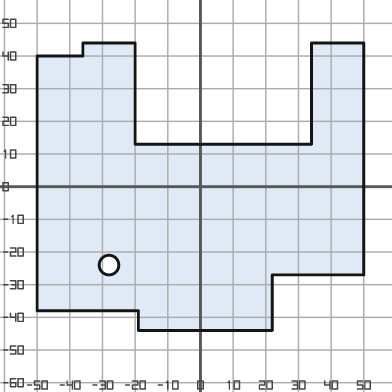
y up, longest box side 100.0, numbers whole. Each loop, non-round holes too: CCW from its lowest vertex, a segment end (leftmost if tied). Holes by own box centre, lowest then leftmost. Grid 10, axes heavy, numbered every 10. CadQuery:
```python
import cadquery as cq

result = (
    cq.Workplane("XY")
    .moveTo(-19.0, -44.0)
    .lineTo(22.0, -44.0)
    .lineTo(22.0, -27.0)
    .lineTo(50.0, -27.0)
    .lineTo(50.0, 44.0)
    .lineTo(34.0, 44.0)
    .lineTo(34.0, 13.0)
    .lineTo(-20.0, 13.0)
    .lineTo(-20.0, 44.0)
    .lineTo(-36.0, 44.0)
    .lineTo(-36.0, 40.0)
    .lineTo(-50.0, 40.0)
    .lineTo(-50.0, -38.0)
    .lineTo(-19.0, -38.0)
    .close()
    .moveTo(-28.0, -24.0)
    .circle(3.0)
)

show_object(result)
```